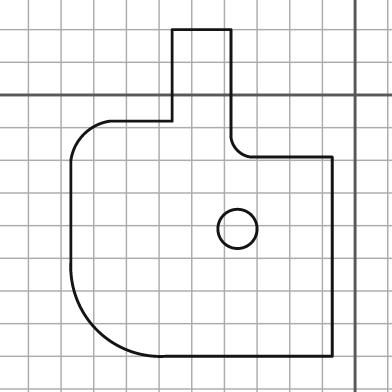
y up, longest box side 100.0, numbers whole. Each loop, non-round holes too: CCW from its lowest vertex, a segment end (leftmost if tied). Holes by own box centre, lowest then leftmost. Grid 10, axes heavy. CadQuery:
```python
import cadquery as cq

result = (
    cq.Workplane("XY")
    .moveTo(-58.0, -80.0)
    .lineTo(-7.0, -80.0)
    .lineTo(-7.0, -19.0)
    .lineTo(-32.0, -19.0)
    .threePointArc((-36.0, -17.0), (-38.0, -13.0))
    .lineTo(-38.0, 20.0)
    .lineTo(-56.0, 20.0)
    .lineTo(-56.0, -8.0)
    .lineTo(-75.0, -8.0)
    .threePointArc((-83.0, -12.0), (-87.0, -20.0))
    .lineTo(-87.0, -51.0)
    .threePointArc((-79.0, -72.0), (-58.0, -80.0))
    .close()
    .moveTo(-36.0, -41.0)
    .circle(6.0)
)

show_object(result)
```